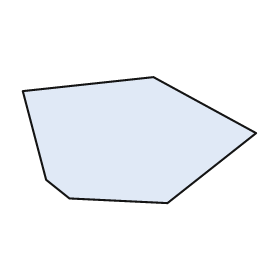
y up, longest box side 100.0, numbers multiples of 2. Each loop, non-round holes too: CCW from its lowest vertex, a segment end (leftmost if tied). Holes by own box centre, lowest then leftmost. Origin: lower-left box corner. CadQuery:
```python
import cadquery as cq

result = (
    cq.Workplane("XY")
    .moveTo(62.0, 0.0)
    .lineTo(100.0, 30.0)
    .lineTo(56.0, 54.0)
    .lineTo(0.0, 48.0)
    .lineTo(10.0, 10.0)
    .lineTo(20.0, 2.0)
    .close()
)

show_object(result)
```